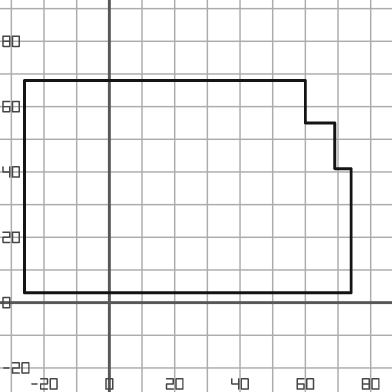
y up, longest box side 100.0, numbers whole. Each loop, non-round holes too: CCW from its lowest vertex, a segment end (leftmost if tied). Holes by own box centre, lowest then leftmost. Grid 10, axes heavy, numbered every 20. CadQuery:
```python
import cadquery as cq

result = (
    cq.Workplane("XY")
    .moveTo(-26.0, 3.0)
    .lineTo(74.0, 3.0)
    .lineTo(74.0, 41.0)
    .lineTo(69.0, 41.0)
    .lineTo(69.0, 55.0)
    .lineTo(60.0, 55.0)
    .lineTo(60.0, 68.0)
    .lineTo(-26.0, 68.0)
    .close()
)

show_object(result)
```